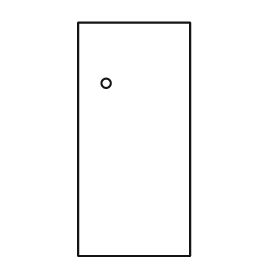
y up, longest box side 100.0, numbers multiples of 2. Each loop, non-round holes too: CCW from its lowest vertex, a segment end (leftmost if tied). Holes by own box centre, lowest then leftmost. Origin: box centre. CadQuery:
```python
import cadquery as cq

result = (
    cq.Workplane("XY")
    .moveTo(-24.0, -50.0)
    .lineTo(24.0, -50.0)
    .lineTo(24.0, 50.0)
    .lineTo(-24.0, 50.0)
    .close()
    .moveTo(-12.0, 24.0)
    .circle(2.0)
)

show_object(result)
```